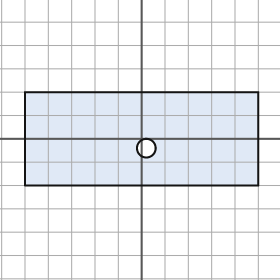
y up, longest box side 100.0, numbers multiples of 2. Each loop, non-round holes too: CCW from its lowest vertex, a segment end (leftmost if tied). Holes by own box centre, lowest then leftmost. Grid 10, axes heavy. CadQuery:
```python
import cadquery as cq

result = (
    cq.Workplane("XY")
    .moveTo(-50.0, -20.0)
    .lineTo(50.0, -20.0)
    .lineTo(50.0, 20.0)
    .lineTo(-50.0, 20.0)
    .close()
    .moveTo(2.0, -4.0)
    .circle(4.0)
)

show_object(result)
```